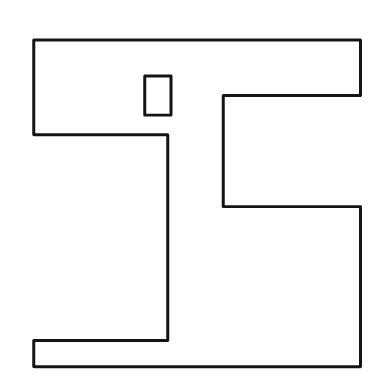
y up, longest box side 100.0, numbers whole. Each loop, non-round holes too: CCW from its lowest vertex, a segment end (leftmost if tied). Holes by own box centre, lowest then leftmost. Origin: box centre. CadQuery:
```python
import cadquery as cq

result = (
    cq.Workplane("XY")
    .moveTo(-50.0, -50.0)
    .lineTo(50.0, -50.0)
    .lineTo(50.0, -1.0)
    .lineTo(8.0, -1.0)
    .lineTo(8.0, 33.0)
    .lineTo(50.0, 33.0)
    .lineTo(50.0, 50.0)
    .lineTo(-50.0, 50.0)
    .lineTo(-50.0, 21.0)
    .lineTo(-9.0, 21.0)
    .lineTo(-9.0, -42.0)
    .lineTo(-50.0, -42.0)
    .close()
    .moveTo(-16.0, 27.0)
    .lineTo(-8.0, 27.0)
    .lineTo(-8.0, 39.0)
    .lineTo(-16.0, 39.0)
    .close()
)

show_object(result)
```